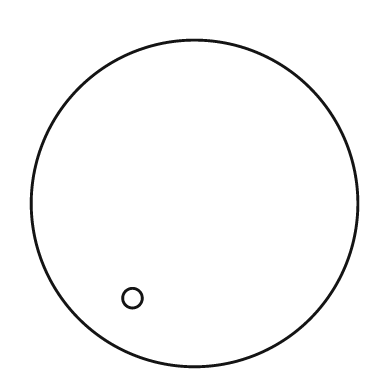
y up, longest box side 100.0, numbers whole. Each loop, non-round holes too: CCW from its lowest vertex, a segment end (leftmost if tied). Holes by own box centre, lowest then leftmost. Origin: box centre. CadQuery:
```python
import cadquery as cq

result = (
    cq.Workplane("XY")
    .moveTo(0.0, 0.0)
    .circle(50.0)
    .moveTo(-19.0, -29.0)
    .circle(3.0)
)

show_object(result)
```